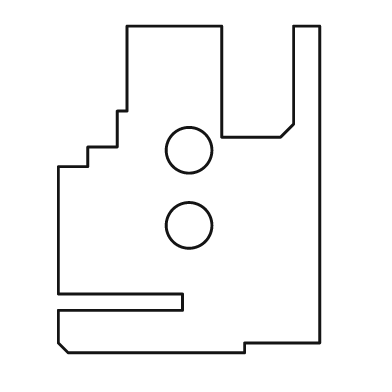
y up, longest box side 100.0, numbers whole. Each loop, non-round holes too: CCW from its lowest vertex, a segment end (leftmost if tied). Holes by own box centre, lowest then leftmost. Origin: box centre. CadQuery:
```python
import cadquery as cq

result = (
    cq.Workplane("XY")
    .moveTo(-37.0, -50.0)
    .lineTo(17.0, -50.0)
    .lineTo(17.0, -47.0)
    .lineTo(40.0, -47.0)
    .lineTo(40.0, 50.0)
    .lineTo(32.0, 50.0)
    .lineTo(32.0, 20.0)
    .lineTo(28.0, 16.0)
    .lineTo(10.0, 16.0)
    .lineTo(10.0, 50.0)
    .lineTo(-19.0, 50.0)
    .lineTo(-19.0, 24.0)
    .lineTo(-22.0, 24.0)
    .lineTo(-22.0, 13.0)
    .lineTo(-31.0, 13.0)
    .lineTo(-31.0, 7.0)
    .lineTo(-40.0, 7.0)
    .lineTo(-40.0, -32.0)
    .lineTo(-2.0, -32.0)
    .lineTo(-2.0, -37.0)
    .lineTo(-40.0, -37.0)
    .lineTo(-40.0, -47.0)
    .close()
    .moveTo(0.0, -11.0)
    .circle(7.0)
    .moveTo(0.0, 12.0)
    .circle(7.0)
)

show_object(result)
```